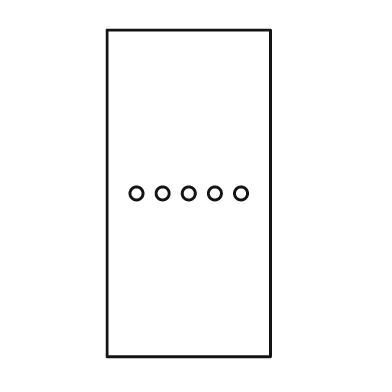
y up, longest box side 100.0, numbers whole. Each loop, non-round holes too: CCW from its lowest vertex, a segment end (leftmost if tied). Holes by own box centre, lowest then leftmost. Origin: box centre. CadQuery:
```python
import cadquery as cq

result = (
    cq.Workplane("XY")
    .moveTo(-25.0, -50.0)
    .lineTo(25.0, -50.0)
    .lineTo(25.0, 50.0)
    .lineTo(-25.0, 50.0)
    .close()
    .moveTo(-16.0, 0.0)
    .circle(2.0)
    .moveTo(-8.0, 0.0)
    .circle(2.0)
    .moveTo(0.0, 0.0)
    .circle(2.0)
    .moveTo(8.0, 0.0)
    .circle(2.0)
    .moveTo(16.0, 0.0)
    .circle(2.0)
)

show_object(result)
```